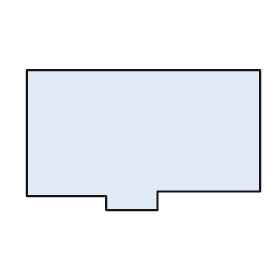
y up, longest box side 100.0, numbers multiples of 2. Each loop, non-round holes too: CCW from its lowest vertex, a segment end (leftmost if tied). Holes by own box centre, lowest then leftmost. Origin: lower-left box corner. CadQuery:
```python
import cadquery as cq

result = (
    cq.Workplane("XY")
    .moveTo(34.0, 0.0)
    .lineTo(56.0, 0.0)
    .lineTo(56.0, 8.0)
    .lineTo(100.0, 8.0)
    .lineTo(100.0, 60.0)
    .lineTo(0.0, 60.0)
    .lineTo(0.0, 6.0)
    .lineTo(34.0, 6.0)
    .close()
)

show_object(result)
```